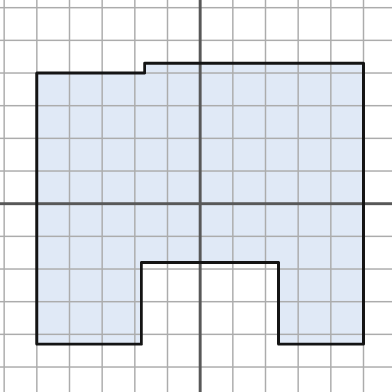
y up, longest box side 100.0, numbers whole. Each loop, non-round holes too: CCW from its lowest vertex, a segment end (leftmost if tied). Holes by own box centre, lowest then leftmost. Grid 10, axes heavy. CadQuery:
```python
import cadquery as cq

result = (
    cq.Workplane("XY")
    .moveTo(-50.0, -43.0)
    .lineTo(-18.0, -43.0)
    .lineTo(-18.0, -18.0)
    .lineTo(24.0, -18.0)
    .lineTo(24.0, -43.0)
    .lineTo(50.0, -43.0)
    .lineTo(50.0, 43.0)
    .lineTo(-17.0, 43.0)
    .lineTo(-17.0, 40.0)
    .lineTo(-50.0, 40.0)
    .close()
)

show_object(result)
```